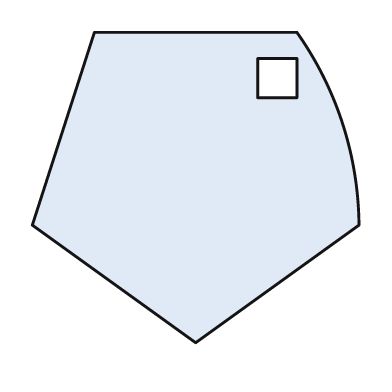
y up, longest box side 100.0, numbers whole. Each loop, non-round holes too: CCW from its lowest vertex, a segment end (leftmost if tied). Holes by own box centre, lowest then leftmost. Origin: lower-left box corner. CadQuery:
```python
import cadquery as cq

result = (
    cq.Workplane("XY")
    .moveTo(50.0, 0.0)
    .lineTo(100.0, 36.0)
    .threePointArc((95.0, 67.0), (81.0, 95.0))
    .lineTo(19.0, 95.0)
    .lineTo(0.0, 36.0)
    .close()
    .moveTo(69.0, 75.0)
    .lineTo(81.0, 75.0)
    .lineTo(81.0, 87.0)
    .lineTo(69.0, 87.0)
    .close()
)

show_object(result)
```